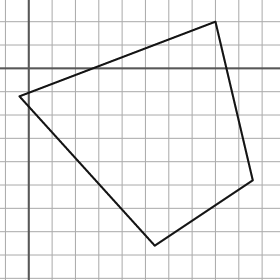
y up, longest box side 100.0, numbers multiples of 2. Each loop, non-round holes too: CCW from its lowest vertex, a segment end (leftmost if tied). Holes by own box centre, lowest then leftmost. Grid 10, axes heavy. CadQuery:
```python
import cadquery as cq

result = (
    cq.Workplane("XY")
    .moveTo(54.0, -76.0)
    .lineTo(96.0, -48.0)
    .lineTo(80.0, 20.0)
    .lineTo(-4.0, -12.0)
    .close()
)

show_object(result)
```